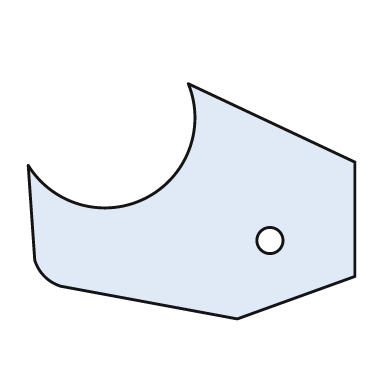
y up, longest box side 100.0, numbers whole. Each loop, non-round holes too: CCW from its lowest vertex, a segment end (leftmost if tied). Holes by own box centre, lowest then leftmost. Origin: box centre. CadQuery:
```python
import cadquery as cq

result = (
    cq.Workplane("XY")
    .moveTo(14.0, -36.0)
    .lineTo(50.0, -23.0)
    .lineTo(50.0, 12.0)
    .lineTo(-1.0, 36.0)
    .threePointArc((-14.0, 1.0), (-50.0, 11.0))
    .lineTo(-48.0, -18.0)
    .threePointArc((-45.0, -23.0), (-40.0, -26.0))
    .close()
    .moveTo(24.0, -12.0)
    .circle(4.0)
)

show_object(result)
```